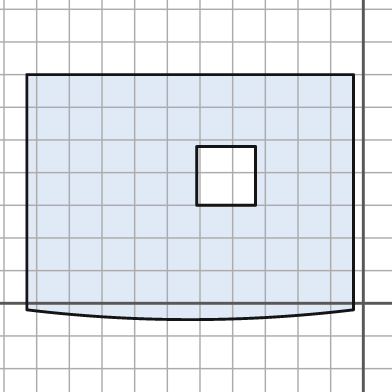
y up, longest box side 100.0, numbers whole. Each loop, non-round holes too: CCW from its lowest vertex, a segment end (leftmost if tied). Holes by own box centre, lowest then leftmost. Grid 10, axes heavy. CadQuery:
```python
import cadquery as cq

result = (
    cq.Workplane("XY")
    .moveTo(-103.0, -2.0)
    .threePointArc((-53.0, -5.0), (-3.0, -2.0))
    .lineTo(-3.0, 70.0)
    .lineTo(-103.0, 70.0)
    .close()
    .moveTo(-51.0, 30.0)
    .lineTo(-33.0, 30.0)
    .lineTo(-33.0, 48.0)
    .lineTo(-51.0, 48.0)
    .close()
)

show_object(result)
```